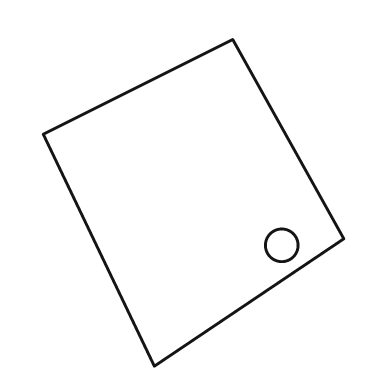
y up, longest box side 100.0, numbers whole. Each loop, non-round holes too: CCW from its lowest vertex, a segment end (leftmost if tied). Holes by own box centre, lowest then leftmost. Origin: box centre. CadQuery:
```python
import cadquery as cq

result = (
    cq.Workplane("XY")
    .moveTo(-12.0, -50.0)
    .lineTo(46.0, -11.0)
    .lineTo(12.0, 50.0)
    .lineTo(-46.0, 21.0)
    .close()
    .moveTo(27.0, -13.0)
    .circle(5.0)
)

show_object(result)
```